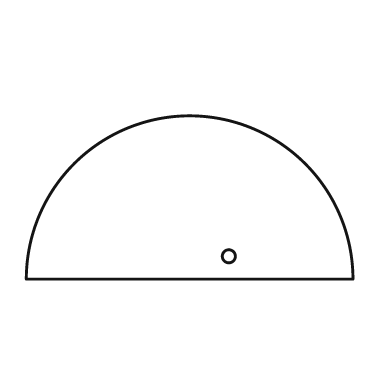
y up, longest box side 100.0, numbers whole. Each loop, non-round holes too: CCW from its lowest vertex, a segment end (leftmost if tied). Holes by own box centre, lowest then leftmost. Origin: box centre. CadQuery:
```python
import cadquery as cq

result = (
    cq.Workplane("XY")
    .moveTo(-50.0, -25.0)
    .lineTo(50.0, -25.0)
    .threePointArc((0.0, 25.0), (-50.0, -25.0))
    .close()
    .moveTo(12.0, -18.0)
    .circle(2.0)
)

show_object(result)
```